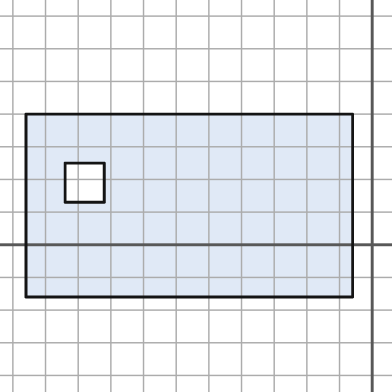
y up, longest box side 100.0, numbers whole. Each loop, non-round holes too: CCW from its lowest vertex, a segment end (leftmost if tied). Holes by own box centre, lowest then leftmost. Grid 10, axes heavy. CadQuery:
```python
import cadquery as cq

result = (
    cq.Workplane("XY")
    .moveTo(-106.0, -16.0)
    .lineTo(-6.0, -16.0)
    .lineTo(-6.0, 40.0)
    .lineTo(-106.0, 40.0)
    .close()
    .moveTo(-94.0, 13.0)
    .lineTo(-82.0, 13.0)
    .lineTo(-82.0, 25.0)
    .lineTo(-94.0, 25.0)
    .close()
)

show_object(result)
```